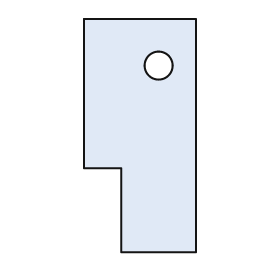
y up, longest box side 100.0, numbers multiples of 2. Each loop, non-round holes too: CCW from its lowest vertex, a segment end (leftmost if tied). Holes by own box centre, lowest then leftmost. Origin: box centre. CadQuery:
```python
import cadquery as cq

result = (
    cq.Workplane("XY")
    .moveTo(-8.0, -50.0)
    .lineTo(24.0, -50.0)
    .lineTo(24.0, 50.0)
    .lineTo(-24.0, 50.0)
    .lineTo(-24.0, -14.0)
    .lineTo(-8.0, -14.0)
    .close()
    .moveTo(8.0, 30.0)
    .circle(6.0)
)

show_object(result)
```